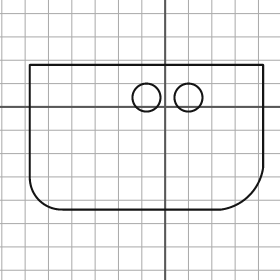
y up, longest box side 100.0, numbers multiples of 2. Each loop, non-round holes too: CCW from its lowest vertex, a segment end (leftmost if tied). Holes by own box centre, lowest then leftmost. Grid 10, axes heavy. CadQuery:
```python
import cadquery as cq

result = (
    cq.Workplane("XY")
    .moveTo(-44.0, -44.0)
    .lineTo(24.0, -44.0)
    .threePointArc((36.0, -38.0), (42.0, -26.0))
    .lineTo(42.0, 18.0)
    .lineTo(-58.0, 18.0)
    .lineTo(-58.0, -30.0)
    .threePointArc((-54.0, -40.0), (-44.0, -44.0))
    .close()
    .moveTo(-8.0, 4.0)
    .circle(6.0)
    .moveTo(10.0, 4.0)
    .circle(6.0)
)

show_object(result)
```